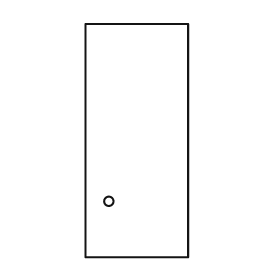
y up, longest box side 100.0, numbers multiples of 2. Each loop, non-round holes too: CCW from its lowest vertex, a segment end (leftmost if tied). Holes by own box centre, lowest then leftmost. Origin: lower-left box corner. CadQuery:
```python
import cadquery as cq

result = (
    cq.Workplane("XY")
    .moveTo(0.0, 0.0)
    .lineTo(44.0, 0.0)
    .lineTo(44.0, 100.0)
    .lineTo(0.0, 100.0)
    .close()
    .moveTo(10.0, 24.0)
    .circle(2.0)
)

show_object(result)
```